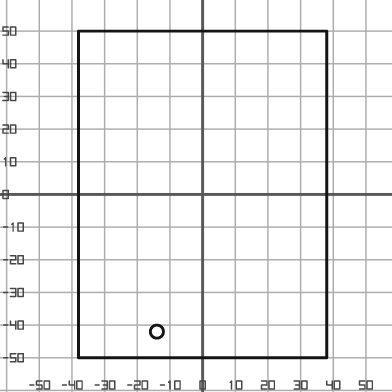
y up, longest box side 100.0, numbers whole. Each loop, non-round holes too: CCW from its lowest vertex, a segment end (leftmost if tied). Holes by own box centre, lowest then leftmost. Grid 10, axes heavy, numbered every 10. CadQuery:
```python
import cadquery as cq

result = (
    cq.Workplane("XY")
    .moveTo(-38.0, -50.0)
    .lineTo(38.0, -50.0)
    .lineTo(38.0, 50.0)
    .lineTo(-38.0, 50.0)
    .close()
    .moveTo(-14.0, -42.0)
    .circle(2.0)
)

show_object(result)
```